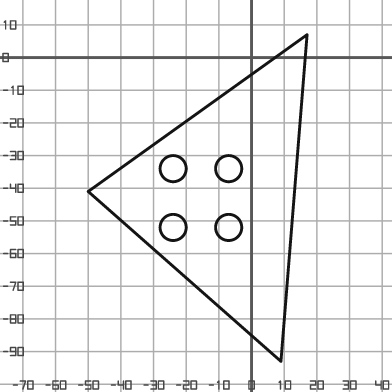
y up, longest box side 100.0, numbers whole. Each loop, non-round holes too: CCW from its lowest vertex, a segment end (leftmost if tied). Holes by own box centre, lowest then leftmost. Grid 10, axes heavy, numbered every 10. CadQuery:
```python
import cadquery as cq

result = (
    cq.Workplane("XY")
    .moveTo(9.0, -93.0)
    .lineTo(17.0, 7.0)
    .lineTo(-50.0, -41.0)
    .close()
    .moveTo(-24.0, -52.0)
    .circle(4.0)
    .moveTo(-7.0, -52.0)
    .circle(4.0)
    .moveTo(-24.0, -34.0)
    .circle(4.0)
    .moveTo(-7.0, -34.0)
    .circle(4.0)
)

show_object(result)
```